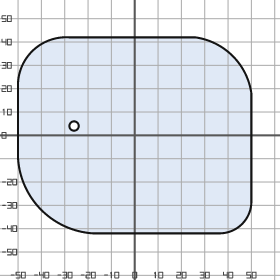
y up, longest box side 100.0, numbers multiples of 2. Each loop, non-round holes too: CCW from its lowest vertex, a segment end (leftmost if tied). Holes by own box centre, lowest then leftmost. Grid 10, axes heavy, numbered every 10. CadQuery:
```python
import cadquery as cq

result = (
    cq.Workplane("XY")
    .moveTo(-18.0, -42.0)
    .lineTo(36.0, -42.0)
    .threePointArc((46.0, -38.0), (50.0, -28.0))
    .lineTo(50.0, 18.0)
    .threePointArc((42.0, 34.0), (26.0, 42.0))
    .lineTo(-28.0, 42.0)
    .threePointArc((-44.0, 36.0), (-50.0, 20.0))
    .lineTo(-50.0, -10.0)
    .threePointArc((-40.0, -32.0), (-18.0, -42.0))
    .close()
    .moveTo(-26.0, 4.0)
    .circle(2.0)
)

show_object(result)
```